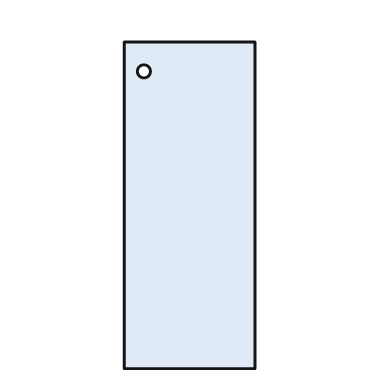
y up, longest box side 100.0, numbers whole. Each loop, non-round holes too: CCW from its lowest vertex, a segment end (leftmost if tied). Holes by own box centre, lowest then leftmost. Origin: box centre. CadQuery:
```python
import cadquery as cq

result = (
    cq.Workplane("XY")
    .moveTo(-20.0, -50.0)
    .lineTo(20.0, -50.0)
    .lineTo(20.0, 50.0)
    .lineTo(-20.0, 50.0)
    .close()
    .moveTo(-14.0, 41.0)
    .circle(2.0)
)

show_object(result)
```